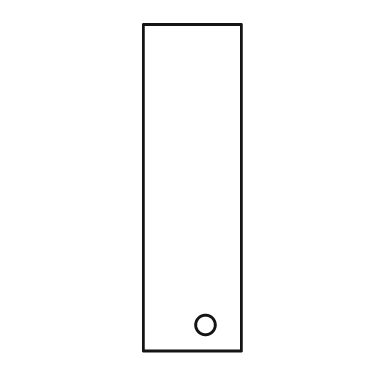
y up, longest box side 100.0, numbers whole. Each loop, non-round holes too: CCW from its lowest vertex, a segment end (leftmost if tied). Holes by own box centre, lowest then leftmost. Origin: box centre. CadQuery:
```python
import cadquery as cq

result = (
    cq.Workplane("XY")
    .moveTo(-15.0, -50.0)
    .lineTo(15.0, -50.0)
    .lineTo(15.0, 50.0)
    .lineTo(-15.0, 50.0)
    .close()
    .moveTo(4.0, -42.0)
    .circle(3.0)
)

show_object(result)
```